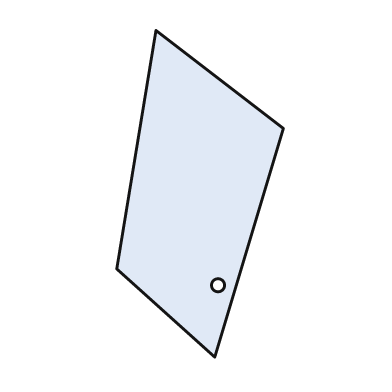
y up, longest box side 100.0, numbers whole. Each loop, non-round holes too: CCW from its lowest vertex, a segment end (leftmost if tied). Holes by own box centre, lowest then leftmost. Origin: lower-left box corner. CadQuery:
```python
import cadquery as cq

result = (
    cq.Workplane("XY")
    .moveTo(30.0, 0.0)
    .lineTo(51.0, 70.0)
    .lineTo(12.0, 100.0)
    .lineTo(0.0, 27.0)
    .close()
    .moveTo(31.0, 22.0)
    .circle(2.0)
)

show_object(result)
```